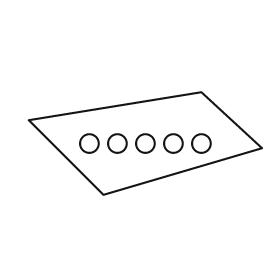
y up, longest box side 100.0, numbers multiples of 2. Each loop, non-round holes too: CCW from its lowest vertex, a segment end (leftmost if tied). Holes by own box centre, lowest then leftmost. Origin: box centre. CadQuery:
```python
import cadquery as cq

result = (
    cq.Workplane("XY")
    .moveTo(-18.0, -22.0)
    .lineTo(50.0, -2.0)
    .lineTo(24.0, 22.0)
    .lineTo(-50.0, 10.0)
    .close()
    .moveTo(-24.0, 0.0)
    .circle(4.0)
    .moveTo(-12.0, 0.0)
    .circle(4.0)
    .moveTo(0.0, 0.0)
    .circle(4.0)
    .moveTo(12.0, 0.0)
    .circle(4.0)
    .moveTo(24.0, 0.0)
    .circle(4.0)
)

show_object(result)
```